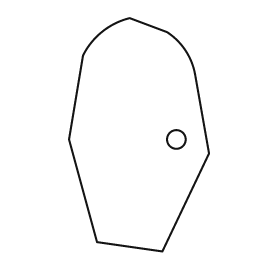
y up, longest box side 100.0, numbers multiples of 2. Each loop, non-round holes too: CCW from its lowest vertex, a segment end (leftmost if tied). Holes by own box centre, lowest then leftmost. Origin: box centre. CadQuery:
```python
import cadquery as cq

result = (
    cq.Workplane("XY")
    .moveTo(10.0, -50.0)
    .lineTo(30.0, -8.0)
    .lineTo(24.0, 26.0)
    .threePointArc((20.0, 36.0), (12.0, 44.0))
    .lineTo(-4.0, 50.0)
    .threePointArc((-16.0, 44.0), (-24.0, 34.0))
    .lineTo(-30.0, -2.0)
    .lineTo(-18.0, -46.0)
    .close()
    .moveTo(16.0, -2.0)
    .circle(4.0)
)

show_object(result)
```